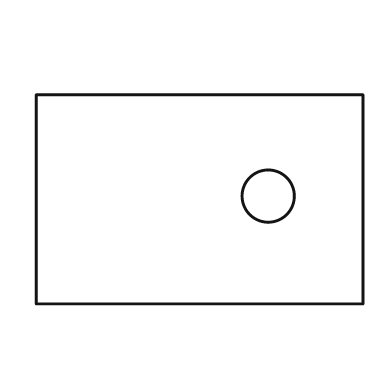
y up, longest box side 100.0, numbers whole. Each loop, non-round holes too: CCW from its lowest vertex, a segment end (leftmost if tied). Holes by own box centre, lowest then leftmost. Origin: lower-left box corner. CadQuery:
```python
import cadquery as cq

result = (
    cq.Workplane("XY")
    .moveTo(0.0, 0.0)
    .lineTo(100.0, 0.0)
    .lineTo(100.0, 64.0)
    .lineTo(0.0, 64.0)
    .close()
    .moveTo(71.0, 33.0)
    .circle(8.0)
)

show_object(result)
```